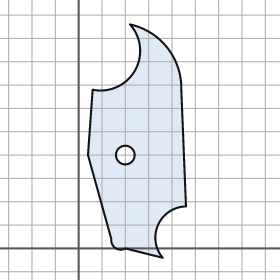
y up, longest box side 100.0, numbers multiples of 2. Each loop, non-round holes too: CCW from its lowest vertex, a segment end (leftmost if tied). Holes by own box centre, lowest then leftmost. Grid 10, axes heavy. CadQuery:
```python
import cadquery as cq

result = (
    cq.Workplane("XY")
    .moveTo(36.0, -4.0)
    .threePointArc((34.0, 10.0), (46.0, 18.0))
    .lineTo(44.0, 68.0)
    .threePointArc((38.0, 86.0), (22.0, 96.0))
    .threePointArc((24.0, 76.0), (6.0, 68.0))
    .lineTo(4.0, 40.0)
    .lineTo(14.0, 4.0)
    .threePointArc((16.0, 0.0), (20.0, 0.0))
    .close()
    .moveTo(20.0, 40.0)
    .circle(4.0)
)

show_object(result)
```